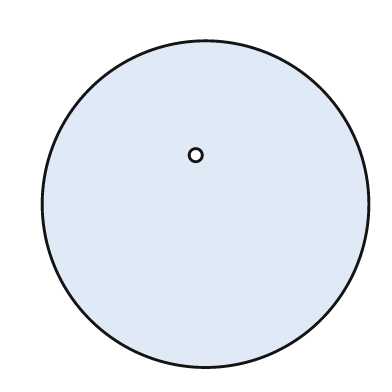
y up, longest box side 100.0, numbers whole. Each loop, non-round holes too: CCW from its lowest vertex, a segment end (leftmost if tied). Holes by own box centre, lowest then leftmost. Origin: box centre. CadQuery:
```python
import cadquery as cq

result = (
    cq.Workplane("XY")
    .moveTo(0.0, 0.0)
    .circle(50.0)
    .moveTo(-3.0, 15.0)
    .circle(2.0)
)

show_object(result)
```